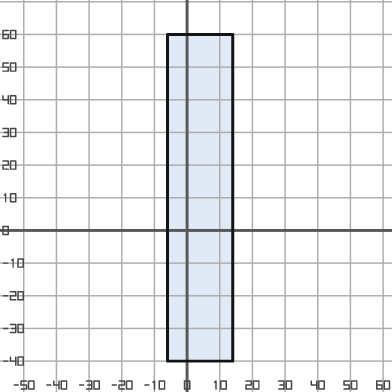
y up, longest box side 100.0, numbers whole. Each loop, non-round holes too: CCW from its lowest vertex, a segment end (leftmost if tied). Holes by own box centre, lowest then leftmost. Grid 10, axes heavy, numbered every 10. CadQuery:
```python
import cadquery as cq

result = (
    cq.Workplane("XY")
    .moveTo(-6.0, -40.0)
    .lineTo(14.0, -40.0)
    .lineTo(14.0, 60.0)
    .lineTo(-6.0, 60.0)
    .close()
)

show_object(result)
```